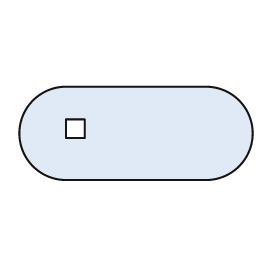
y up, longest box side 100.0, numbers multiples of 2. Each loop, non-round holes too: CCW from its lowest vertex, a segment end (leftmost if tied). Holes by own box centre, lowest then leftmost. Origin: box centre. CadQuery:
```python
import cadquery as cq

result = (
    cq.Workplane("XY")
    .moveTo(-30.0, -20.0)
    .lineTo(30.0, -20.0)
    .threePointArc((50.0, 0.0), (30.0, 20.0))
    .lineTo(-30.0, 20.0)
    .threePointArc((-50.0, 0.0), (-30.0, -20.0))
    .close()
    .moveTo(-30.0, -2.0)
    .lineTo(-22.0, -2.0)
    .lineTo(-22.0, 6.0)
    .lineTo(-30.0, 6.0)
    .close()
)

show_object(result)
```